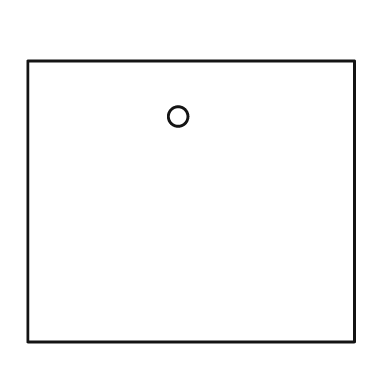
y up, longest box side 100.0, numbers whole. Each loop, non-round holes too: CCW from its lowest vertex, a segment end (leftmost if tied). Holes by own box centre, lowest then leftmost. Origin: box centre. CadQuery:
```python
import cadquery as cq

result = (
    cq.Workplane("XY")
    .moveTo(-50.0, -43.0)
    .lineTo(50.0, -43.0)
    .lineTo(50.0, 43.0)
    .lineTo(-50.0, 43.0)
    .close()
    .moveTo(-4.0, 26.0)
    .circle(3.0)
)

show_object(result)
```